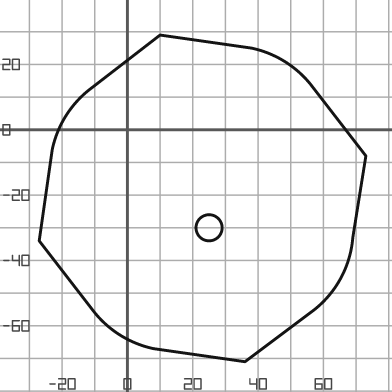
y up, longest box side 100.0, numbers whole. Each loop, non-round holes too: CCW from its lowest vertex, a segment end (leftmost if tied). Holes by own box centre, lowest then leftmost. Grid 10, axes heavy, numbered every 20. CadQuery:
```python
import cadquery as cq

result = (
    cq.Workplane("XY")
    .moveTo(36.0, -71.0)
    .lineTo(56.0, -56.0)
    .threePointArc((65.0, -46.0), (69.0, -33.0))
    .lineTo(73.0, -8.0)
    .lineTo(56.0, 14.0)
    .threePointArc((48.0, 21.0), (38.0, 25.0))
    .lineTo(10.0, 29.0)
    .lineTo(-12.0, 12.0)
    .threePointArc((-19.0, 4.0), (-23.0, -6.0))
    .lineTo(-27.0, -34.0)
    .lineTo(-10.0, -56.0)
    .threePointArc((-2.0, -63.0), (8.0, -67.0))
    .close()
    .moveTo(25.0, -30.0)
    .circle(4.0)
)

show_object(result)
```